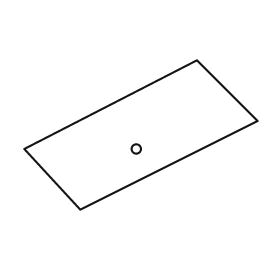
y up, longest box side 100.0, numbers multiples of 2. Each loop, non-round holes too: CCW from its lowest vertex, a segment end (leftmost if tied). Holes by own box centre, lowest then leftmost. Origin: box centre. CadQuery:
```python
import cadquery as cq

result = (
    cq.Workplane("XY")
    .moveTo(-26.0, -32.0)
    .lineTo(50.0, 6.0)
    .lineTo(24.0, 32.0)
    .lineTo(-50.0, -6.0)
    .close()
    .moveTo(-2.0, -6.0)
    .circle(2.0)
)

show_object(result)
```